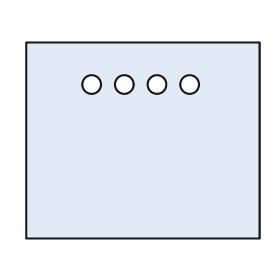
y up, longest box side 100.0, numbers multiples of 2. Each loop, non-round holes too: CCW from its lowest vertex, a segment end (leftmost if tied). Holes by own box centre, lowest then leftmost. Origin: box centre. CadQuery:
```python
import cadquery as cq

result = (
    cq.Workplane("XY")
    .moveTo(-50.0, -42.0)
    .lineTo(50.0, -42.0)
    .lineTo(50.0, 42.0)
    .lineTo(-50.0, 42.0)
    .close()
    .moveTo(-22.0, 24.0)
    .circle(4.0)
    .moveTo(-8.0, 24.0)
    .circle(4.0)
    .moveTo(6.0, 24.0)
    .circle(4.0)
    .moveTo(20.0, 24.0)
    .circle(4.0)
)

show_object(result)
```